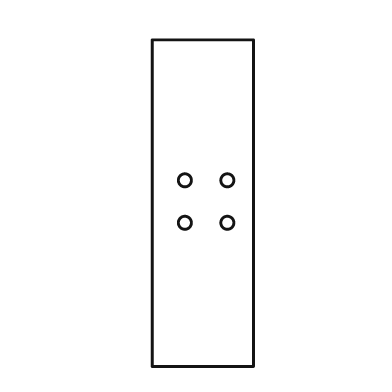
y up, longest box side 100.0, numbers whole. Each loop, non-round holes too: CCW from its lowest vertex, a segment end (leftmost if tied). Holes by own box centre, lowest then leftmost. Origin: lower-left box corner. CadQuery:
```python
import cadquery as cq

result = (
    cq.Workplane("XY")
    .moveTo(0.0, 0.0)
    .lineTo(31.0, 0.0)
    .lineTo(31.0, 100.0)
    .lineTo(0.0, 100.0)
    .close()
    .moveTo(10.0, 44.0)
    .circle(2.0)
    .moveTo(23.0, 44.0)
    .circle(2.0)
    .moveTo(10.0, 57.0)
    .circle(2.0)
    .moveTo(23.0, 57.0)
    .circle(2.0)
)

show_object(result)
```